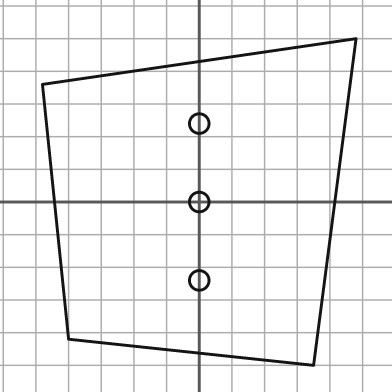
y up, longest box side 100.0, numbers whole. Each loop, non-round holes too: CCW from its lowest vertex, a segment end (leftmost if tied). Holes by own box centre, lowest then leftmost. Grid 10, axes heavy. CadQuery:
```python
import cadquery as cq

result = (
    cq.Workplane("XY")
    .moveTo(35.0, -50.0)
    .lineTo(48.0, 50.0)
    .lineTo(-48.0, 36.0)
    .lineTo(-40.0, -42.0)
    .close()
    .moveTo(0.0, -24.0)
    .circle(3.0)
    .moveTo(0.0, 0.0)
    .circle(3.0)
    .moveTo(0.0, 24.0)
    .circle(3.0)
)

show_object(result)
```